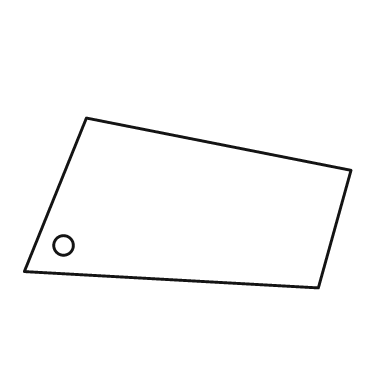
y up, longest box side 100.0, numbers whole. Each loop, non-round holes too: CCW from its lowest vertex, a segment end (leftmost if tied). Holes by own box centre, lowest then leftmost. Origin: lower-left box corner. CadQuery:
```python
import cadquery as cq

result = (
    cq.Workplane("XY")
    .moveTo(90.0, 0.0)
    .lineTo(100.0, 36.0)
    .lineTo(19.0, 52.0)
    .lineTo(0.0, 5.0)
    .close()
    .moveTo(12.0, 13.0)
    .circle(3.0)
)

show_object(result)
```